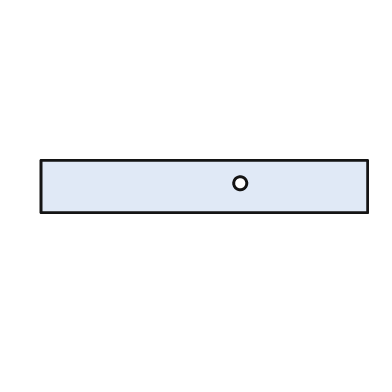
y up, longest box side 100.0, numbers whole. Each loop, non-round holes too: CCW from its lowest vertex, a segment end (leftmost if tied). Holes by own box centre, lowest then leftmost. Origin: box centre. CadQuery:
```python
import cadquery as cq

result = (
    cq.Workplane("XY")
    .moveTo(-50.0, -8.0)
    .lineTo(50.0, -8.0)
    .lineTo(50.0, 8.0)
    .lineTo(-50.0, 8.0)
    .close()
    .moveTo(11.0, 1.0)
    .circle(2.0)
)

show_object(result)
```